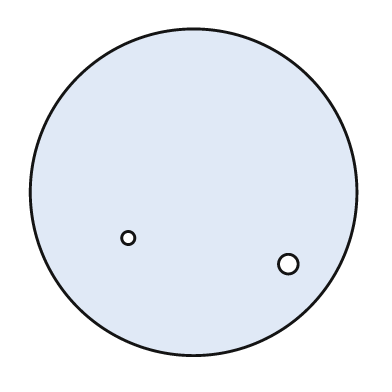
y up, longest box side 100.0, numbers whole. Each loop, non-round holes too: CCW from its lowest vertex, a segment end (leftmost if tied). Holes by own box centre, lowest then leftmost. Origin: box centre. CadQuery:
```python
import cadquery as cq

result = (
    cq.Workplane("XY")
    .moveTo(0.0, 0.0)
    .circle(50.0)
    .moveTo(29.0, -22.0)
    .circle(3.0)
    .moveTo(-20.0, -14.0)
    .circle(2.0)
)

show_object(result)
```